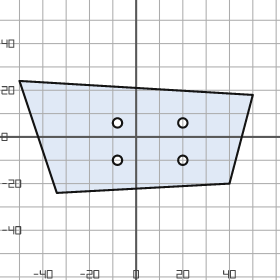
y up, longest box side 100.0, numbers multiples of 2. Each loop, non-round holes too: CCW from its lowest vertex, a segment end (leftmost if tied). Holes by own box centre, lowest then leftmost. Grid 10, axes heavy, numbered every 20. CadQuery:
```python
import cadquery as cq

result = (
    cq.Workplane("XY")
    .moveTo(-34.0, -24.0)
    .lineTo(40.0, -20.0)
    .lineTo(50.0, 18.0)
    .lineTo(-50.0, 24.0)
    .close()
    .moveTo(-8.0, -10.0)
    .circle(2.0)
    .moveTo(20.0, -10.0)
    .circle(2.0)
    .moveTo(-8.0, 6.0)
    .circle(2.0)
    .moveTo(20.0, 6.0)
    .circle(2.0)
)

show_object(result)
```